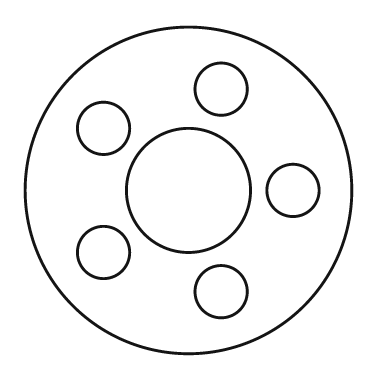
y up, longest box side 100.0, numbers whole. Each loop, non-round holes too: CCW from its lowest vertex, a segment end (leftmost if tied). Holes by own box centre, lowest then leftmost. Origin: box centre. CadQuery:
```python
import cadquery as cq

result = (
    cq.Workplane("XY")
    .moveTo(0.0, 0.0)
    .circle(50.0)
    .moveTo(10.0, -31.0)
    .circle(8.0)
    .moveTo(-26.0, -19.0)
    .circle(8.0)
    .moveTo(0.0, 0.0)
    .circle(19.0)
    .moveTo(32.0, 0.0)
    .circle(8.0)
    .moveTo(-26.0, 19.0)
    .circle(8.0)
    .moveTo(10.0, 31.0)
    .circle(8.0)
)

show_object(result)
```